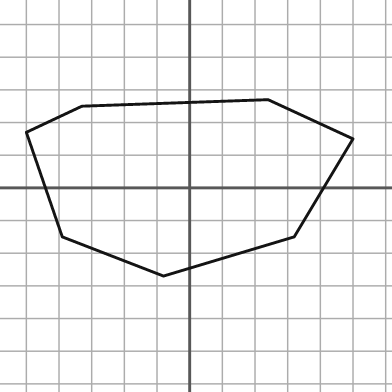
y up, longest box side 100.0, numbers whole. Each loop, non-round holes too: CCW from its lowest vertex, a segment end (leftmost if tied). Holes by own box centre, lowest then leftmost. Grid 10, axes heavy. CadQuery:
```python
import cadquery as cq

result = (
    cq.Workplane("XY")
    .moveTo(-8.0, -27.0)
    .lineTo(32.0, -15.0)
    .lineTo(50.0, 15.0)
    .lineTo(24.0, 27.0)
    .lineTo(-33.0, 25.0)
    .lineTo(-50.0, 17.0)
    .lineTo(-39.0, -15.0)
    .close()
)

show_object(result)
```